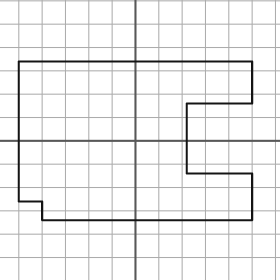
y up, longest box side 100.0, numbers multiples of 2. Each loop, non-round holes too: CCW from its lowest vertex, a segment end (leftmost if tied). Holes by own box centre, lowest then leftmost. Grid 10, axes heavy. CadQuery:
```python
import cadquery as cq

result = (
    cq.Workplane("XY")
    .moveTo(-40.0, -34.0)
    .lineTo(50.0, -34.0)
    .lineTo(50.0, -14.0)
    .lineTo(22.0, -14.0)
    .lineTo(22.0, 16.0)
    .lineTo(50.0, 16.0)
    .lineTo(50.0, 34.0)
    .lineTo(-50.0, 34.0)
    .lineTo(-50.0, -26.0)
    .lineTo(-40.0, -26.0)
    .close()
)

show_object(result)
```